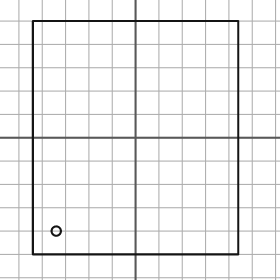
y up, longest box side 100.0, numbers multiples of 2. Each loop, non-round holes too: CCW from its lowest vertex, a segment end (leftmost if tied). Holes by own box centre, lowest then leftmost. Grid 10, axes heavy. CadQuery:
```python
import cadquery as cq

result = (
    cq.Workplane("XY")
    .moveTo(-44.0, -50.0)
    .lineTo(44.0, -50.0)
    .lineTo(44.0, 50.0)
    .lineTo(-44.0, 50.0)
    .close()
    .moveTo(-34.0, -40.0)
    .circle(2.0)
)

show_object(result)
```